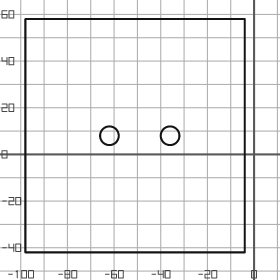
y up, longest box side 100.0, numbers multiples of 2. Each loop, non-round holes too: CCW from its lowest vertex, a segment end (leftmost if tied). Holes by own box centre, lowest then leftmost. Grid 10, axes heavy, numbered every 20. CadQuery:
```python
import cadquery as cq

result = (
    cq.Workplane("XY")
    .moveTo(-98.0, -42.0)
    .lineTo(-4.0, -42.0)
    .lineTo(-4.0, 58.0)
    .lineTo(-98.0, 58.0)
    .close()
    .moveTo(-62.0, 8.0)
    .circle(4.0)
    .moveTo(-36.0, 8.0)
    .circle(4.0)
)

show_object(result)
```